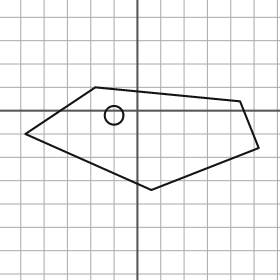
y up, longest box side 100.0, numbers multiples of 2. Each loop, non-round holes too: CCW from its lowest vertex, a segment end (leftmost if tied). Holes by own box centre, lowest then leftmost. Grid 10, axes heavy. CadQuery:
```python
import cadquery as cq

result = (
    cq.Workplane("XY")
    .moveTo(6.0, -34.0)
    .lineTo(52.0, -16.0)
    .lineTo(44.0, 4.0)
    .lineTo(-18.0, 10.0)
    .lineTo(-48.0, -10.0)
    .close()
    .moveTo(-10.0, -2.0)
    .circle(4.0)
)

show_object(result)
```